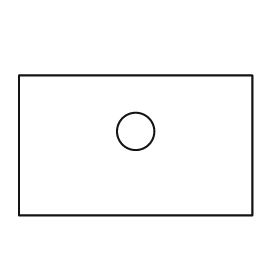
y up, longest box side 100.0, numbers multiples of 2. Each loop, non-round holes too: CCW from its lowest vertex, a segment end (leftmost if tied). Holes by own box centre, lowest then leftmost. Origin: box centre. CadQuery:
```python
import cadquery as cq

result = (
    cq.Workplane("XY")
    .moveTo(-50.0, -30.0)
    .lineTo(50.0, -30.0)
    .lineTo(50.0, 30.0)
    .lineTo(-50.0, 30.0)
    .close()
    .moveTo(0.0, 6.0)
    .circle(8.0)
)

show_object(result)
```